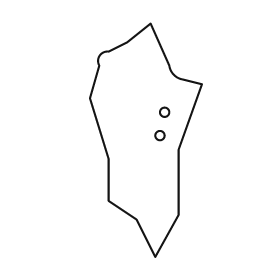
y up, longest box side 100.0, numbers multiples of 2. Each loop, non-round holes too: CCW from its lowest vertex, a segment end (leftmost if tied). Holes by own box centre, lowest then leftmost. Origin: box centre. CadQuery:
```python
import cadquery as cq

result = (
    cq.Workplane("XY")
    .moveTo(4.0, -50.0)
    .lineTo(14.0, -32.0)
    .lineTo(14.0, -4.0)
    .lineTo(24.0, 24.0)
    .lineTo(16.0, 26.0)
    .threePointArc((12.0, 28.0), (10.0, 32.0))
    .lineTo(2.0, 50.0)
    .lineTo(-8.0, 42.0)
    .lineTo(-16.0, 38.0)
    .threePointArc((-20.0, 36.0), (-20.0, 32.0))
    .lineTo(-24.0, 18.0)
    .lineTo(-16.0, -8.0)
    .lineTo(-16.0, -26.0)
    .lineTo(-4.0, -34.0)
    .close()
    .moveTo(6.0, 2.0)
    .circle(2.0)
    .moveTo(8.0, 12.0)
    .circle(2.0)
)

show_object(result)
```